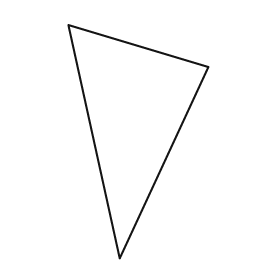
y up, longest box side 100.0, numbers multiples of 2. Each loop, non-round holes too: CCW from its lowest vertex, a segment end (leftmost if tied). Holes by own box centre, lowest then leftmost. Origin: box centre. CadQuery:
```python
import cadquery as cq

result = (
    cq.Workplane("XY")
    .moveTo(-8.0, -50.0)
    .lineTo(30.0, 32.0)
    .lineTo(-30.0, 50.0)
    .close()
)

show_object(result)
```